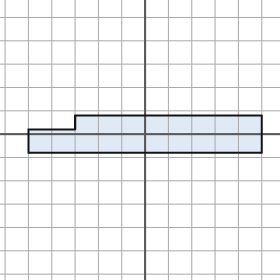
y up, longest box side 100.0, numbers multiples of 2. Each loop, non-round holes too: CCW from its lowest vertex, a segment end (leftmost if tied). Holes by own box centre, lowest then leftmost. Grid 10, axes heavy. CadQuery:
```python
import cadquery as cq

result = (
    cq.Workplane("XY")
    .moveTo(-50.0, -8.0)
    .lineTo(50.0, -8.0)
    .lineTo(50.0, 8.0)
    .lineTo(-30.0, 8.0)
    .lineTo(-30.0, 2.0)
    .lineTo(-50.0, 2.0)
    .close()
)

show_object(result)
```